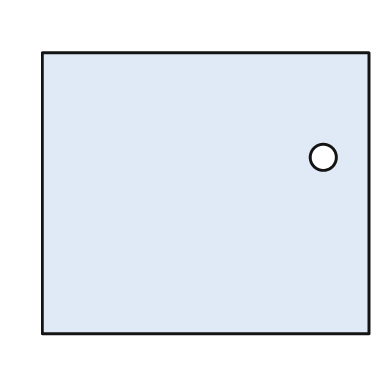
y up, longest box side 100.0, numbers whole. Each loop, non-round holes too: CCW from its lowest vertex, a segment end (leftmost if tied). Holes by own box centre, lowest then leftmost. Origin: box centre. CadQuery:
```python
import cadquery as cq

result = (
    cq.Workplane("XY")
    .moveTo(-50.0, -43.0)
    .lineTo(50.0, -43.0)
    .lineTo(50.0, 43.0)
    .lineTo(-50.0, 43.0)
    .close()
    .moveTo(36.0, 11.0)
    .circle(4.0)
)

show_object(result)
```